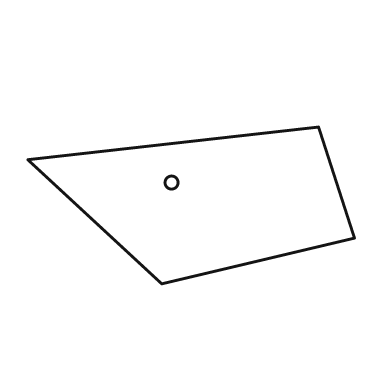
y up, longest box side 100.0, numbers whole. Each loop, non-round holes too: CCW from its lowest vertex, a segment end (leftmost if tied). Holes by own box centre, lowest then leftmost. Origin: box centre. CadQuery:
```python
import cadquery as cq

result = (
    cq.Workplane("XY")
    .moveTo(-9.0, -24.0)
    .lineTo(50.0, -10.0)
    .lineTo(39.0, 24.0)
    .lineTo(-50.0, 14.0)
    .close()
    .moveTo(-6.0, 7.0)
    .circle(2.0)
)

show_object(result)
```